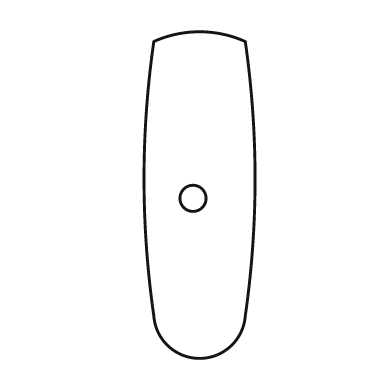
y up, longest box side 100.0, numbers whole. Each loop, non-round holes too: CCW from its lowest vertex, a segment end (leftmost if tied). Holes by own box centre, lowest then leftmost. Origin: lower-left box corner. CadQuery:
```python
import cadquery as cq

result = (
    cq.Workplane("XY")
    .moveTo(3.0, 13.0)
    .threePointArc((17.0, 0.0), (31.0, 13.0))
    .threePointArc((34.0, 55.0), (31.0, 97.0))
    .threePointArc((17.0, 100.0), (3.0, 97.0))
    .threePointArc((0.0, 55.0), (3.0, 13.0))
    .close()
    .moveTo(15.0, 49.0)
    .circle(4.0)
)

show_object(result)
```